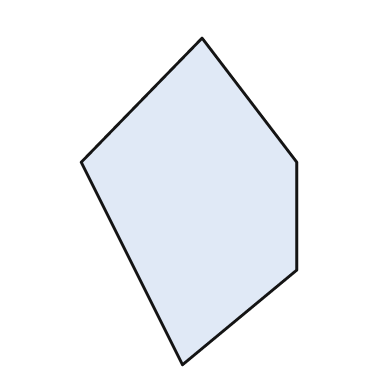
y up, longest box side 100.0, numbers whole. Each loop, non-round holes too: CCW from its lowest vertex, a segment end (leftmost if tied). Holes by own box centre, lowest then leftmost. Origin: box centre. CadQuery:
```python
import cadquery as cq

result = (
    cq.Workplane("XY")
    .moveTo(-2.0, -50.0)
    .lineTo(33.0, -21.0)
    .lineTo(33.0, 12.0)
    .lineTo(4.0, 50.0)
    .lineTo(-33.0, 12.0)
    .close()
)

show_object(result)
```